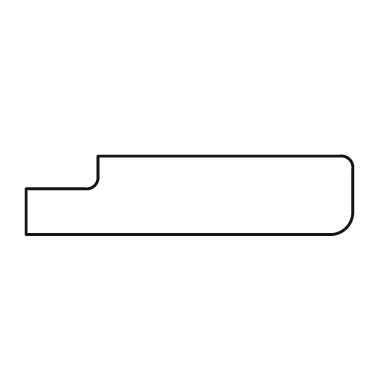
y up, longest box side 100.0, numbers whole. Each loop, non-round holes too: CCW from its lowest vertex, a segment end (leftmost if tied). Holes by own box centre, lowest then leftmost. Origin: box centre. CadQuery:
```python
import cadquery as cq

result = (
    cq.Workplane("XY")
    .moveTo(-50.0, -12.0)
    .lineTo(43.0, -12.0)
    .threePointArc((48.0, -10.0), (50.0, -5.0))
    .lineTo(50.0, 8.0)
    .threePointArc((49.0, 11.0), (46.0, 12.0))
    .lineTo(-28.0, 12.0)
    .lineTo(-28.0, 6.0)
    .threePointArc((-29.0, 3.0), (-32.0, 2.0))
    .lineTo(-50.0, 2.0)
    .close()
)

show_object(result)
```